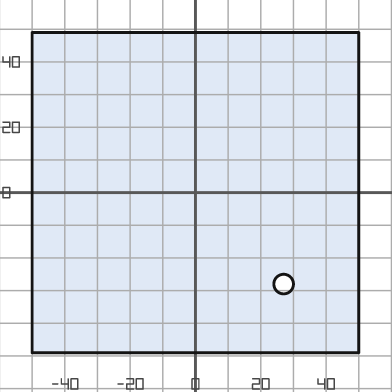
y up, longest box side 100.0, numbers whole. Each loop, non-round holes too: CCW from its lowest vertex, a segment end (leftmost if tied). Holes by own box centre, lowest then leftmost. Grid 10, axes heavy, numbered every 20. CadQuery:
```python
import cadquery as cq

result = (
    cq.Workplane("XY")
    .moveTo(-50.0, -49.0)
    .lineTo(50.0, -49.0)
    .lineTo(50.0, 49.0)
    .lineTo(-50.0, 49.0)
    .close()
    .moveTo(27.0, -28.0)
    .circle(3.0)
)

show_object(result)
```